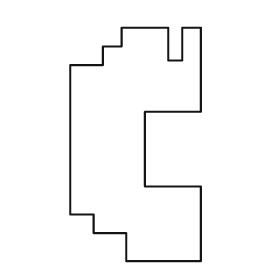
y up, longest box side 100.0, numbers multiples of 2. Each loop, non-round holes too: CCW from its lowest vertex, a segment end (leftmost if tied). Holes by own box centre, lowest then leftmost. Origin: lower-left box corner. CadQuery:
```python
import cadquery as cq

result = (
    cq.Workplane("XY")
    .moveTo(24.0, 0.0)
    .lineTo(56.0, 0.0)
    .lineTo(56.0, 32.0)
    .lineTo(32.0, 32.0)
    .lineTo(32.0, 64.0)
    .lineTo(56.0, 64.0)
    .lineTo(56.0, 100.0)
    .lineTo(48.0, 100.0)
    .lineTo(48.0, 86.0)
    .lineTo(42.0, 86.0)
    .lineTo(42.0, 100.0)
    .lineTo(22.0, 100.0)
    .lineTo(22.0, 92.0)
    .lineTo(14.0, 92.0)
    .lineTo(14.0, 84.0)
    .lineTo(0.0, 84.0)
    .lineTo(0.0, 20.0)
    .lineTo(10.0, 20.0)
    .lineTo(10.0, 12.0)
    .lineTo(24.0, 12.0)
    .close()
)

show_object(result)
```